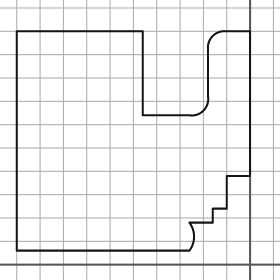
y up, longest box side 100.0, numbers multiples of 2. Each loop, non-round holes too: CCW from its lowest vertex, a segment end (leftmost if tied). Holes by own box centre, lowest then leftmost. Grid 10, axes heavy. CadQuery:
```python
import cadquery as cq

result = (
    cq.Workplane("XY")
    .moveTo(-100.0, 6.0)
    .lineTo(-26.0, 6.0)
    .threePointArc((-24.0, 12.0), (-26.0, 18.0))
    .lineTo(-16.0, 18.0)
    .lineTo(-16.0, 24.0)
    .lineTo(-10.0, 24.0)
    .lineTo(-10.0, 38.0)
    .lineTo(0.0, 38.0)
    .lineTo(0.0, 100.0)
    .lineTo(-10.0, 100.0)
    .threePointArc((-16.0, 98.0), (-18.0, 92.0))
    .lineTo(-18.0, 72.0)
    .threePointArc((-20.0, 66.0), (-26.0, 64.0))
    .lineTo(-46.0, 64.0)
    .lineTo(-46.0, 100.0)
    .lineTo(-100.0, 100.0)
    .close()
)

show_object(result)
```